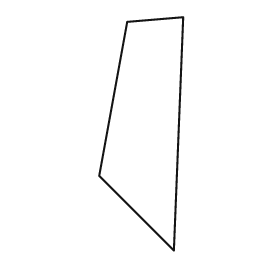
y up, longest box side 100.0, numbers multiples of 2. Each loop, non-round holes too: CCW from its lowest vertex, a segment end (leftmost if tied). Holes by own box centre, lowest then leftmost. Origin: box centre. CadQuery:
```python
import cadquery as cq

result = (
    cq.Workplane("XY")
    .moveTo(14.0, -50.0)
    .lineTo(18.0, 50.0)
    .lineTo(-6.0, 48.0)
    .lineTo(-18.0, -18.0)
    .close()
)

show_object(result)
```